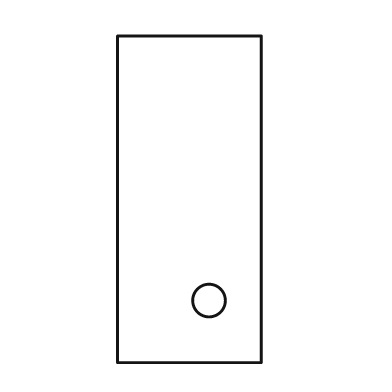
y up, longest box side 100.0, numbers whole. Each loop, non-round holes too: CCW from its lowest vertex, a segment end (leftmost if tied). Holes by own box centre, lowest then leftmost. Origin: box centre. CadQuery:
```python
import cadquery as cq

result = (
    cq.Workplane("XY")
    .moveTo(-22.0, -50.0)
    .lineTo(22.0, -50.0)
    .lineTo(22.0, 50.0)
    .lineTo(-22.0, 50.0)
    .close()
    .moveTo(6.0, -31.0)
    .circle(5.0)
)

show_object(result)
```